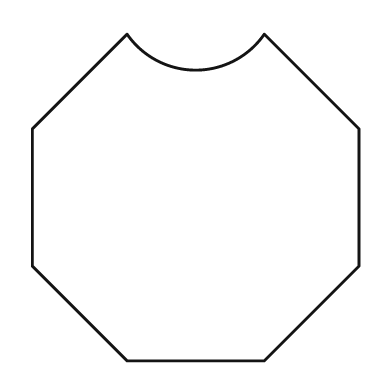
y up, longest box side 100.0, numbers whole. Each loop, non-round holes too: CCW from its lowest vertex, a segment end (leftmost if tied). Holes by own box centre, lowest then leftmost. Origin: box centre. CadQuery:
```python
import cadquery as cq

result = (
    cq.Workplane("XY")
    .moveTo(-21.0, -50.0)
    .lineTo(21.0, -50.0)
    .lineTo(50.0, -21.0)
    .lineTo(50.0, 21.0)
    .lineTo(21.0, 50.0)
    .threePointArc((0.0, 39.0), (-21.0, 50.0))
    .lineTo(-50.0, 21.0)
    .lineTo(-50.0, -21.0)
    .close()
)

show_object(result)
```